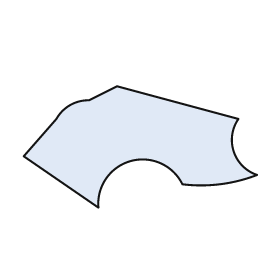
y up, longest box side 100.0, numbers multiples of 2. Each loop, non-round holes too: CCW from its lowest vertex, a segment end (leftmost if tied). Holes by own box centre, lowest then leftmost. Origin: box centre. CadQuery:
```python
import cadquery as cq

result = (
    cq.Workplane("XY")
    .moveTo(-18.0, -26.0)
    .threePointArc((-4.0, -6.0), (18.0, -16.0))
    .threePointArc((34.0, -16.0), (50.0, -12.0))
    .threePointArc((40.0, -2.0), (42.0, 12.0))
    .lineTo(-10.0, 26.0)
    .lineTo(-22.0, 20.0)
    .threePointArc((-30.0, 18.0), (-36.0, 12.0))
    .lineTo(-50.0, -4.0)
    .close()
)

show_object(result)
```